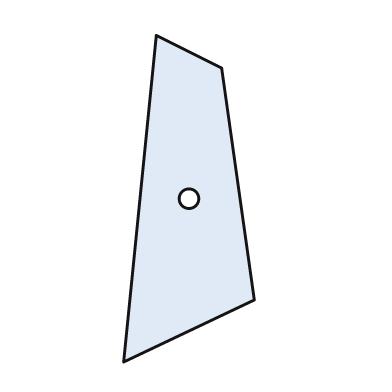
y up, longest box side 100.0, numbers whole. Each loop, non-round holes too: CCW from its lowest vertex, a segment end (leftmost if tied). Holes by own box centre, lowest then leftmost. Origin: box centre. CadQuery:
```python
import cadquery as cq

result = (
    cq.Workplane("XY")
    .moveTo(-20.0, -50.0)
    .lineTo(20.0, -31.0)
    .lineTo(10.0, 40.0)
    .lineTo(-10.0, 50.0)
    .close()
    .moveTo(0.0, 0.0)
    .circle(3.0)
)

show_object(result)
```